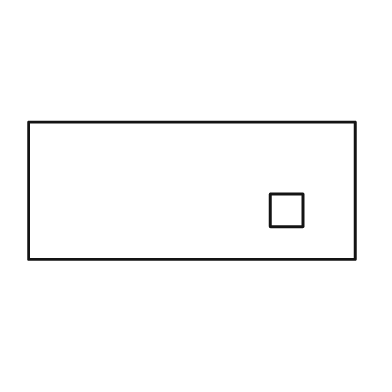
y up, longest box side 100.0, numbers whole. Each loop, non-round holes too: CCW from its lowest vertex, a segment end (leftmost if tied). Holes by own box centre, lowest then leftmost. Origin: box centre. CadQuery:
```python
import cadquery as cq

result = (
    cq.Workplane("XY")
    .moveTo(-50.0, -21.0)
    .lineTo(50.0, -21.0)
    .lineTo(50.0, 21.0)
    .lineTo(-50.0, 21.0)
    .close()
    .moveTo(24.0, -11.0)
    .lineTo(34.0, -11.0)
    .lineTo(34.0, -1.0)
    .lineTo(24.0, -1.0)
    .close()
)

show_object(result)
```